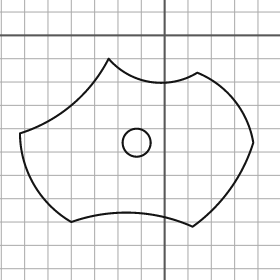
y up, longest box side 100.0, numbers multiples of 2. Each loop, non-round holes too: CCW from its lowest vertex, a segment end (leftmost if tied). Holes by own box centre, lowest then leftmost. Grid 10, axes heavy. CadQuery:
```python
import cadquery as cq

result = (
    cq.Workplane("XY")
    .moveTo(12.0, -82.0)
    .threePointArc((28.0, -66.0), (38.0, -46.0))
    .threePointArc((30.0, -28.0), (14.0, -16.0))
    .threePointArc((-6.0, -20.0), (-24.0, -10.0))
    .threePointArc((-40.0, -30.0), (-62.0, -42.0))
    .threePointArc((-56.0, -64.0), (-40.0, -80.0))
    .threePointArc((-14.0, -76.0), (12.0, -82.0))
    .close()
    .moveTo(-12.0, -46.0)
    .circle(6.0)
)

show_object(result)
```